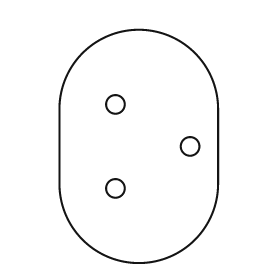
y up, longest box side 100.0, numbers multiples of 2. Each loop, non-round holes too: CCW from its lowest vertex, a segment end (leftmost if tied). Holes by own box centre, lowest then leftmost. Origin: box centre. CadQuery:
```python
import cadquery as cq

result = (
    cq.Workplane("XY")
    .moveTo(-34.0, -16.0)
    .threePointArc((0.0, -50.0), (34.0, -16.0))
    .lineTo(34.0, 16.0)
    .threePointArc((0.0, 50.0), (-34.0, 16.0))
    .close()
    .moveTo(-10.0, -18.0)
    .circle(4.0)
    .moveTo(22.0, 0.0)
    .circle(4.0)
    .moveTo(-10.0, 18.0)
    .circle(4.0)
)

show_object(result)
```